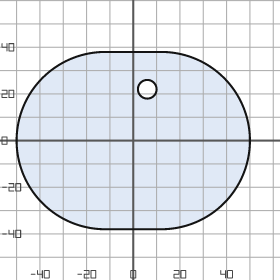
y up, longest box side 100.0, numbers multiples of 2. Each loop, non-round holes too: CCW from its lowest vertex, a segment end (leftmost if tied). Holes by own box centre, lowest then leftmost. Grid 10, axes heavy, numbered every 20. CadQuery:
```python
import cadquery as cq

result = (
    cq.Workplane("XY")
    .moveTo(-12.0, -38.0)
    .lineTo(12.0, -38.0)
    .threePointArc((50.0, 0.0), (12.0, 38.0))
    .lineTo(-12.0, 38.0)
    .threePointArc((-50.0, 0.0), (-12.0, -38.0))
    .close()
    .moveTo(6.0, 22.0)
    .circle(4.0)
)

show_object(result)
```